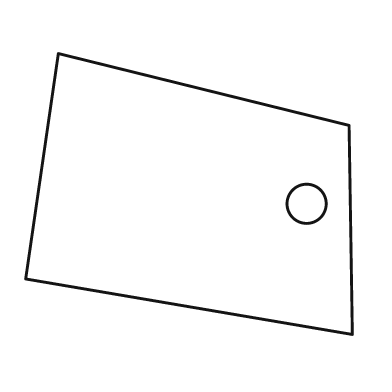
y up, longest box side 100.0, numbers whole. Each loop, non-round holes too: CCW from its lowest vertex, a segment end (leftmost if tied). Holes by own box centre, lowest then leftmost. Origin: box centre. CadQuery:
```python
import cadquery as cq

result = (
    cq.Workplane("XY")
    .moveTo(50.0, -43.0)
    .lineTo(49.0, 21.0)
    .lineTo(-40.0, 43.0)
    .lineTo(-50.0, -26.0)
    .close()
    .moveTo(36.0, -3.0)
    .circle(6.0)
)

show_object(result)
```